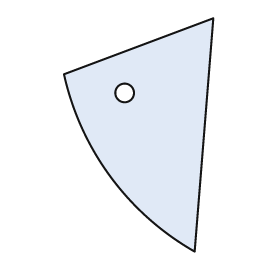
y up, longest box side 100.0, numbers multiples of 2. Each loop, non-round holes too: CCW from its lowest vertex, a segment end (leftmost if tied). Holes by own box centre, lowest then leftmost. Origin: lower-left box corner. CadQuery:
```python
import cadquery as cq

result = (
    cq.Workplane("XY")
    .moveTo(56.0, 0.0)
    .lineTo(64.0, 100.0)
    .lineTo(0.0, 76.0)
    .threePointArc((20.0, 32.0), (56.0, 0.0))
    .close()
    .moveTo(26.0, 68.0)
    .circle(4.0)
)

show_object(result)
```